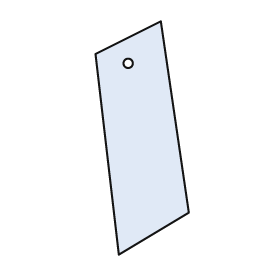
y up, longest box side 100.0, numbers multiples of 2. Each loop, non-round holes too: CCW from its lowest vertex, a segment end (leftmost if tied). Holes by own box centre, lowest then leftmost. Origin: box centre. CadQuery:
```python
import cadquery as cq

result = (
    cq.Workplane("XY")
    .moveTo(-10.0, -50.0)
    .lineTo(20.0, -32.0)
    .lineTo(8.0, 50.0)
    .lineTo(-20.0, 36.0)
    .close()
    .moveTo(-6.0, 32.0)
    .circle(2.0)
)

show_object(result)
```